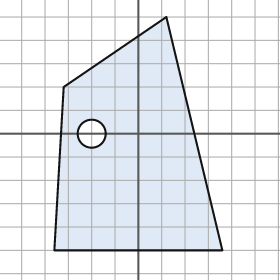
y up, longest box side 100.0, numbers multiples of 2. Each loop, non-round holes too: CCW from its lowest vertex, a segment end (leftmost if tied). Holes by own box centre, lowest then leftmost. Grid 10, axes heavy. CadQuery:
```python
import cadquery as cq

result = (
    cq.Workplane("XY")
    .moveTo(-36.0, -50.0)
    .lineTo(36.0, -50.0)
    .lineTo(12.0, 50.0)
    .lineTo(-32.0, 20.0)
    .close()
    .moveTo(-20.0, 0.0)
    .circle(6.0)
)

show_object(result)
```